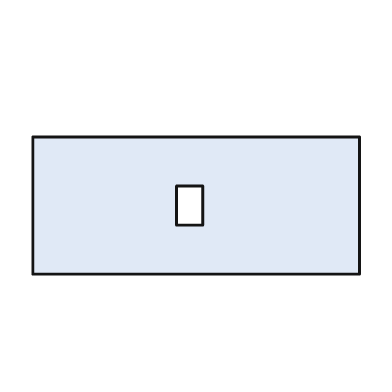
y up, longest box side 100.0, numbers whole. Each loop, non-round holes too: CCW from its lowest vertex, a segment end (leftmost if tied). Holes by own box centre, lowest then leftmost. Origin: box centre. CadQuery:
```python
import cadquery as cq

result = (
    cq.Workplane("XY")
    .moveTo(-50.0, -21.0)
    .lineTo(50.0, -21.0)
    .lineTo(50.0, 21.0)
    .lineTo(-50.0, 21.0)
    .close()
    .moveTo(-6.0, -6.0)
    .lineTo(2.0, -6.0)
    .lineTo(2.0, 6.0)
    .lineTo(-6.0, 6.0)
    .close()
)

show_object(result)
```